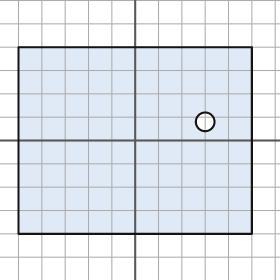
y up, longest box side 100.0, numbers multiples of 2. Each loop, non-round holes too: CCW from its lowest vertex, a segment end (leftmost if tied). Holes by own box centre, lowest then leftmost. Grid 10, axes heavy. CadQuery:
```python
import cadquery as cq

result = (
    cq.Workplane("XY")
    .moveTo(-50.0, -40.0)
    .lineTo(50.0, -40.0)
    .lineTo(50.0, 40.0)
    .lineTo(-50.0, 40.0)
    .close()
    .moveTo(30.0, 8.0)
    .circle(4.0)
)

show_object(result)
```